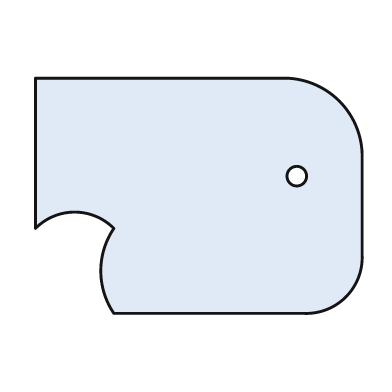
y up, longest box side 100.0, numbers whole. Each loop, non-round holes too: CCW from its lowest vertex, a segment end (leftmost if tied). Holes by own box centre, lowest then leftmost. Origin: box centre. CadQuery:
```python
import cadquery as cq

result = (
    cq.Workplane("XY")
    .moveTo(-26.0, -36.0)
    .lineTo(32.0, -36.0)
    .threePointArc((45.0, -31.0), (50.0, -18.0))
    .lineTo(50.0, 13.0)
    .threePointArc((43.0, 29.0), (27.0, 36.0))
    .lineTo(-50.0, 36.0)
    .lineTo(-50.0, -10.0)
    .threePointArc((-38.0, -5.0), (-26.0, -10.0))
    .threePointArc((-30.0, -23.0), (-26.0, -36.0))
    .close()
    .moveTo(30.0, 6.0)
    .circle(3.0)
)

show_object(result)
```